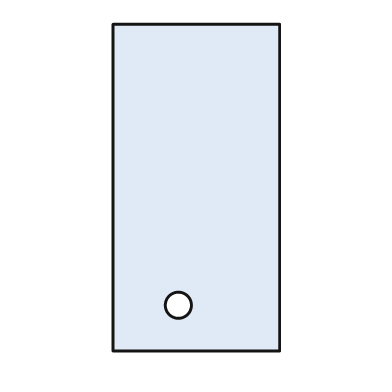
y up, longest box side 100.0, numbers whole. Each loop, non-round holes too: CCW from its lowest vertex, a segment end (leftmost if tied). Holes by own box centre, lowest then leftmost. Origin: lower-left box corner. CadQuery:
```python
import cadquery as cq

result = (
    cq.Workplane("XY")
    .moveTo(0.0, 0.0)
    .lineTo(51.0, 0.0)
    .lineTo(51.0, 100.0)
    .lineTo(0.0, 100.0)
    .close()
    .moveTo(20.0, 14.0)
    .circle(4.0)
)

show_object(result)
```